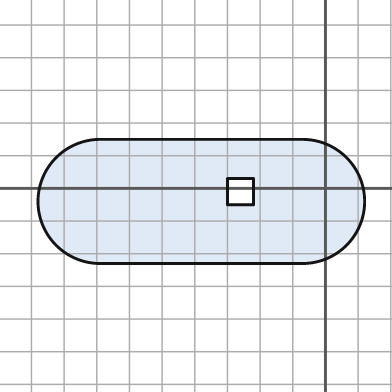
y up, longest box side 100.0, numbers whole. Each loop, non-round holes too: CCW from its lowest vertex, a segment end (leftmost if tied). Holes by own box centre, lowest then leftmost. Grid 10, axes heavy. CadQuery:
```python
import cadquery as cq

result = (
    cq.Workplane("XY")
    .moveTo(-69.0, -23.0)
    .lineTo(-7.0, -23.0)
    .threePointArc((12.0, -4.0), (-7.0, 15.0))
    .lineTo(-69.0, 15.0)
    .threePointArc((-88.0, -4.0), (-69.0, -23.0))
    .close()
    .moveTo(-30.0, -5.0)
    .lineTo(-22.0, -5.0)
    .lineTo(-22.0, 3.0)
    .lineTo(-30.0, 3.0)
    .close()
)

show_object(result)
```